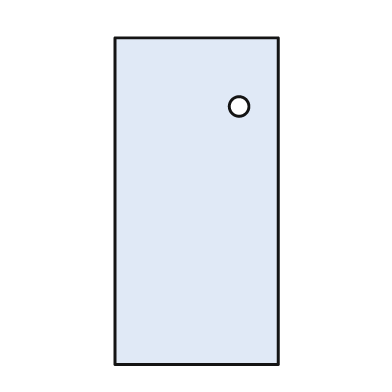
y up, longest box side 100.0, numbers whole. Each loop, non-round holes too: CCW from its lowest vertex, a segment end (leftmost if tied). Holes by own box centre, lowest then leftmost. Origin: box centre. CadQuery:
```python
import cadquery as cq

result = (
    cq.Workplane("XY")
    .moveTo(-25.0, -50.0)
    .lineTo(25.0, -50.0)
    .lineTo(25.0, 50.0)
    .lineTo(-25.0, 50.0)
    .close()
    .moveTo(13.0, 29.0)
    .circle(3.0)
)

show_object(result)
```